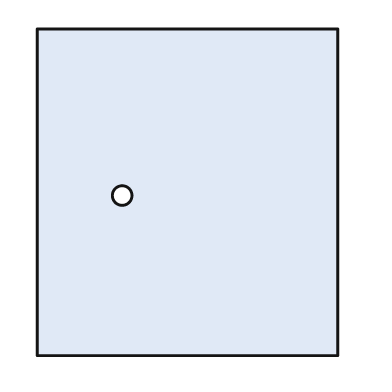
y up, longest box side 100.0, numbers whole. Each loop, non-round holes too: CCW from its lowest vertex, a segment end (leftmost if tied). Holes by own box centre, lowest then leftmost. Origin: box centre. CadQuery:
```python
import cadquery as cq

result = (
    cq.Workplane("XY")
    .moveTo(-46.0, -50.0)
    .lineTo(46.0, -50.0)
    .lineTo(46.0, 50.0)
    .lineTo(-46.0, 50.0)
    .close()
    .moveTo(-20.0, -1.0)
    .circle(3.0)
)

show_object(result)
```